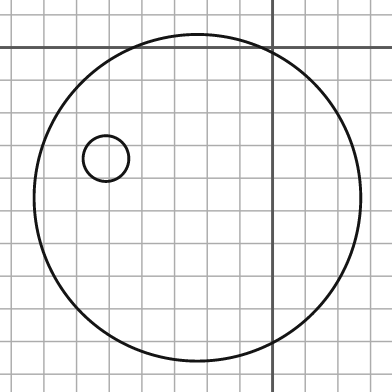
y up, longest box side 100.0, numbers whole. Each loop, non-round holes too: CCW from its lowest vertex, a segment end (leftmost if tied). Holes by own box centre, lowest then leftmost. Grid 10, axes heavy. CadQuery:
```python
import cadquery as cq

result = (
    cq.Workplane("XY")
    .moveTo(-23.0, -46.0)
    .circle(50.0)
    .moveTo(-51.0, -34.0)
    .circle(7.0)
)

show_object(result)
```